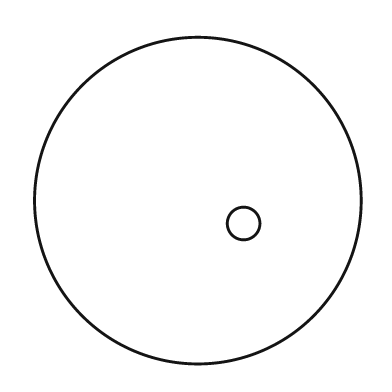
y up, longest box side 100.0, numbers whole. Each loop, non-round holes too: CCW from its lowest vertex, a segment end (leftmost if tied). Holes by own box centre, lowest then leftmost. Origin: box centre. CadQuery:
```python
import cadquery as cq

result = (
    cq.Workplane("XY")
    .moveTo(0.0, 0.0)
    .circle(50.0)
    .moveTo(14.0, -7.0)
    .circle(5.0)
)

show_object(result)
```